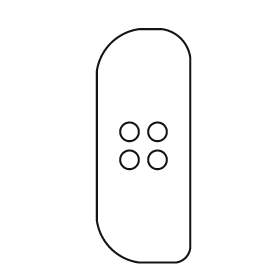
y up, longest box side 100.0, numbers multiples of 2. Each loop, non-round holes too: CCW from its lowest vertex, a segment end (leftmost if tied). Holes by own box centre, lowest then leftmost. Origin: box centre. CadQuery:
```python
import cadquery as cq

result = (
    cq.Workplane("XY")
    .moveTo(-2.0, -50.0)
    .lineTo(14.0, -50.0)
    .threePointArc((18.0, -48.0), (20.0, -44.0))
    .lineTo(20.0, 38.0)
    .threePointArc((16.0, 46.0), (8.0, 50.0))
    .lineTo(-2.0, 50.0)
    .threePointArc((-14.0, 44.0), (-20.0, 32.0))
    .lineTo(-20.0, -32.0)
    .threePointArc((-14.0, -44.0), (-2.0, -50.0))
    .close()
    .moveTo(-6.0, -6.0)
    .circle(4.0)
    .moveTo(6.0, -6.0)
    .circle(4.0)
    .moveTo(-6.0, 6.0)
    .circle(4.0)
    .moveTo(6.0, 6.0)
    .circle(4.0)
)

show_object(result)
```